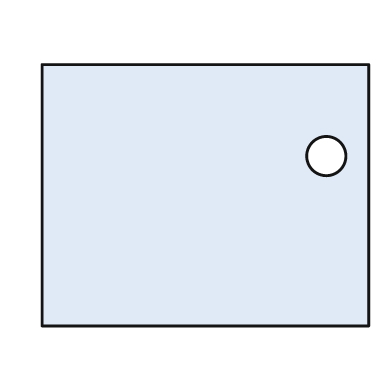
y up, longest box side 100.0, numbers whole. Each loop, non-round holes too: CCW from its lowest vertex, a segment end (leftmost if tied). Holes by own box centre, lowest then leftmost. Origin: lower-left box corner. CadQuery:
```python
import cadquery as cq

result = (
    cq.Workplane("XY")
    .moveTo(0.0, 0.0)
    .lineTo(100.0, 0.0)
    .lineTo(100.0, 80.0)
    .lineTo(0.0, 80.0)
    .close()
    .moveTo(87.0, 52.0)
    .circle(6.0)
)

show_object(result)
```